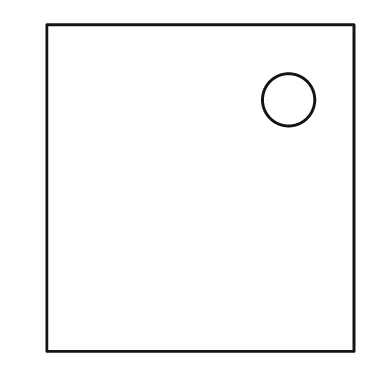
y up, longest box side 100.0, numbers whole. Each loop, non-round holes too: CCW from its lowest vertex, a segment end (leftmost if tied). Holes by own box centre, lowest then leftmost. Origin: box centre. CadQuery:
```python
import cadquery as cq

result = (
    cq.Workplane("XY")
    .moveTo(-47.0, -50.0)
    .lineTo(47.0, -50.0)
    .lineTo(47.0, 50.0)
    .lineTo(-47.0, 50.0)
    .close()
    .moveTo(27.0, 27.0)
    .circle(8.0)
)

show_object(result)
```